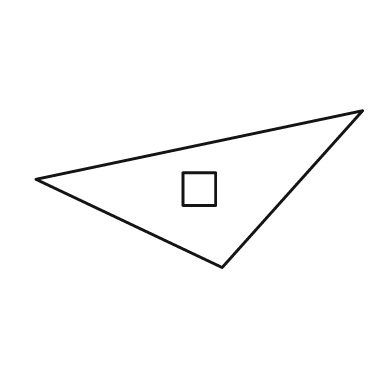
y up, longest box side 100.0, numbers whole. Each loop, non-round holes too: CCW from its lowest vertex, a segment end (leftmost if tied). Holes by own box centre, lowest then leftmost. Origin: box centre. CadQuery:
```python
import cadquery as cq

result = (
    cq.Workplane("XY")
    .moveTo(7.0, -24.0)
    .lineTo(50.0, 24.0)
    .lineTo(-50.0, 3.0)
    .close()
    .moveTo(-5.0, -5.0)
    .lineTo(5.0, -5.0)
    .lineTo(5.0, 5.0)
    .lineTo(-5.0, 5.0)
    .close()
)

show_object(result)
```